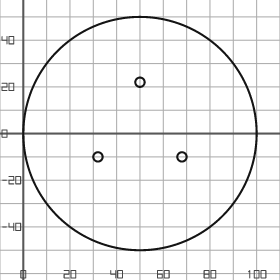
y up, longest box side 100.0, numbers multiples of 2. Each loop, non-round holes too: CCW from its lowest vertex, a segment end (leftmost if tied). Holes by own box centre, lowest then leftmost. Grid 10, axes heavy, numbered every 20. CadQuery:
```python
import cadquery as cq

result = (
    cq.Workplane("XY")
    .moveTo(50.0, 0.0)
    .circle(50.0)
    .moveTo(32.0, -10.0)
    .circle(2.0)
    .moveTo(68.0, -10.0)
    .circle(2.0)
    .moveTo(50.0, 22.0)
    .circle(2.0)
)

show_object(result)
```